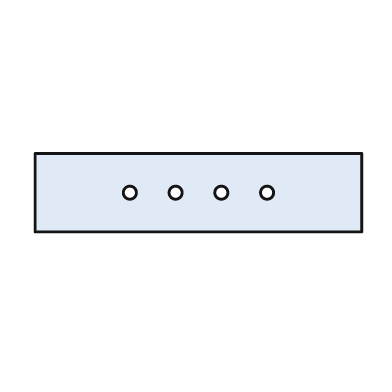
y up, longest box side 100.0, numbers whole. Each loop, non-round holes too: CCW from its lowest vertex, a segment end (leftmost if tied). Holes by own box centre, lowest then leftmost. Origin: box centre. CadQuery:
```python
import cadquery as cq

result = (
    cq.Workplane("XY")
    .moveTo(-50.0, -12.0)
    .lineTo(50.0, -12.0)
    .lineTo(50.0, 12.0)
    .lineTo(-50.0, 12.0)
    .close()
    .moveTo(-21.0, 0.0)
    .circle(2.0)
    .moveTo(-7.0, 0.0)
    .circle(2.0)
    .moveTo(7.0, 0.0)
    .circle(2.0)
    .moveTo(21.0, 0.0)
    .circle(2.0)
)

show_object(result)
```